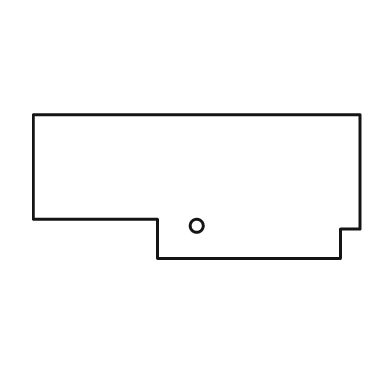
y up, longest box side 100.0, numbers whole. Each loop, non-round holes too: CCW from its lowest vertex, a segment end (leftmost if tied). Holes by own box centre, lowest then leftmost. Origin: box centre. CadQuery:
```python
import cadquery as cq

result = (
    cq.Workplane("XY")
    .moveTo(-12.0, -22.0)
    .lineTo(44.0, -22.0)
    .lineTo(44.0, -13.0)
    .lineTo(50.0, -13.0)
    .lineTo(50.0, 22.0)
    .lineTo(-50.0, 22.0)
    .lineTo(-50.0, -10.0)
    .lineTo(-12.0, -10.0)
    .close()
    .moveTo(0.0, -12.0)
    .circle(2.0)
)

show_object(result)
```